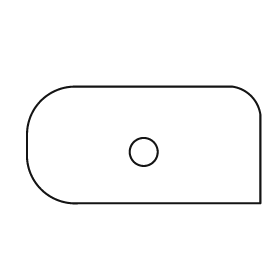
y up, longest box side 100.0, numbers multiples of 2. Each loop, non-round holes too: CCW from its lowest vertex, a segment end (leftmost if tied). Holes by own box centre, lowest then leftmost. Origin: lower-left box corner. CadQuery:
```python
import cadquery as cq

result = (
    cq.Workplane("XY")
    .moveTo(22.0, 0.0)
    .lineTo(100.0, 0.0)
    .lineTo(100.0, 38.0)
    .threePointArc((96.0, 46.0), (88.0, 50.0))
    .lineTo(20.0, 50.0)
    .threePointArc((6.0, 44.0), (0.0, 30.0))
    .lineTo(0.0, 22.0)
    .threePointArc((6.0, 6.0), (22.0, 0.0))
    .close()
    .moveTo(50.0, 22.0)
    .circle(6.0)
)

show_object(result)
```